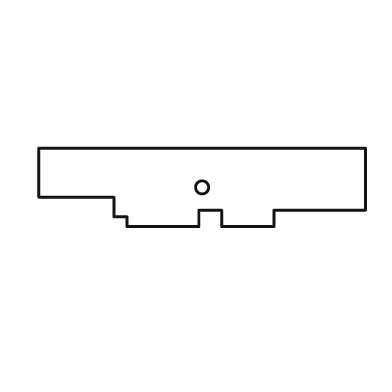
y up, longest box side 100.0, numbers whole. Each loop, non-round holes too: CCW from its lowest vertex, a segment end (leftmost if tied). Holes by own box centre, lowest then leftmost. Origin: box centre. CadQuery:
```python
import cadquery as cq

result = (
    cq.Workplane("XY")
    .moveTo(-23.0, -12.0)
    .lineTo(-1.0, -12.0)
    .lineTo(-1.0, -7.0)
    .lineTo(6.0, -7.0)
    .lineTo(6.0, -12.0)
    .lineTo(22.0, -12.0)
    .lineTo(22.0, -7.0)
    .lineTo(50.0, -7.0)
    .lineTo(50.0, 12.0)
    .lineTo(-50.0, 12.0)
    .lineTo(-50.0, -3.0)
    .lineTo(-27.0, -3.0)
    .lineTo(-27.0, -9.0)
    .lineTo(-23.0, -9.0)
    .close()
    .moveTo(0.0, 0.0)
    .circle(2.0)
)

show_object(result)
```